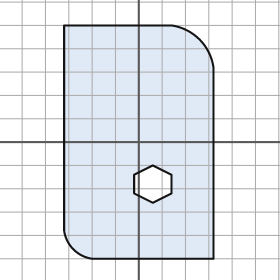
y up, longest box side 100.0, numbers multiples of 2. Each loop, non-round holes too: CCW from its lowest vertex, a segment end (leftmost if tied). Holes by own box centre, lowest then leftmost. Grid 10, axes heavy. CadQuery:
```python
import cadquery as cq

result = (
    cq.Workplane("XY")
    .moveTo(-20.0, -50.0)
    .lineTo(32.0, -50.0)
    .lineTo(32.0, 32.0)
    .threePointArc((26.0, 44.0), (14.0, 50.0))
    .lineTo(-32.0, 50.0)
    .lineTo(-32.0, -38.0)
    .threePointArc((-28.0, -46.0), (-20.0, -50.0))
    .close()
    .moveTo(6.0, -26.0)
    .lineTo(14.0, -22.0)
    .lineTo(14.0, -14.0)
    .lineTo(6.0, -10.0)
    .lineTo(-2.0, -14.0)
    .lineTo(-2.0, -22.0)
    .close()
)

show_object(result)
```